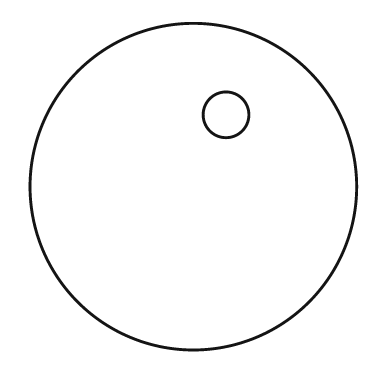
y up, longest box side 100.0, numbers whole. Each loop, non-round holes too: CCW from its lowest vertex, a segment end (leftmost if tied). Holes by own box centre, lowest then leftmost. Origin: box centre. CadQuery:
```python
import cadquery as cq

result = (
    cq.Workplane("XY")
    .moveTo(0.0, 0.0)
    .circle(50.0)
    .moveTo(10.0, 22.0)
    .circle(7.0)
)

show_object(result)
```